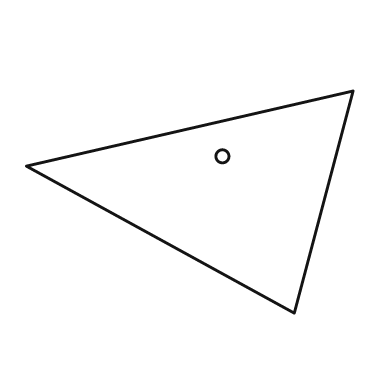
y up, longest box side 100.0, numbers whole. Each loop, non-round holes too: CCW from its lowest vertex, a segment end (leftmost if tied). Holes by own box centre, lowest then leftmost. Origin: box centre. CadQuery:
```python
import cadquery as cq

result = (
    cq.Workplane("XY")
    .moveTo(32.0, -34.0)
    .lineTo(50.0, 34.0)
    .lineTo(-50.0, 11.0)
    .close()
    .moveTo(10.0, 14.0)
    .circle(2.0)
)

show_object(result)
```